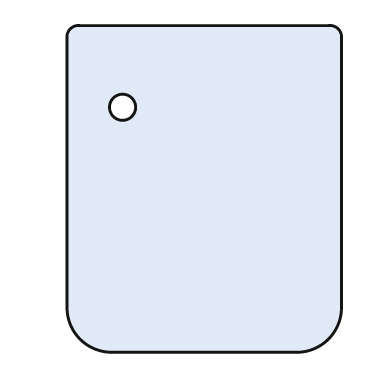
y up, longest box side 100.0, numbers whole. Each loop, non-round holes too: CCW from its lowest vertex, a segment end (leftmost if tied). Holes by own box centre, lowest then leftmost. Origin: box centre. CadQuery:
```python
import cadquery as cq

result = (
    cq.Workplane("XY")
    .moveTo(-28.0, -50.0)
    .lineTo(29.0, -50.0)
    .threePointArc((38.0, -46.0), (42.0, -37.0))
    .lineTo(42.0, 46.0)
    .threePointArc((41.0, 49.0), (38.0, 50.0))
    .lineTo(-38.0, 50.0)
    .threePointArc((-41.0, 49.0), (-42.0, 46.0))
    .lineTo(-42.0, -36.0)
    .threePointArc((-38.0, -46.0), (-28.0, -50.0))
    .close()
    .moveTo(-25.0, 25.0)
    .circle(4.0)
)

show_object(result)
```